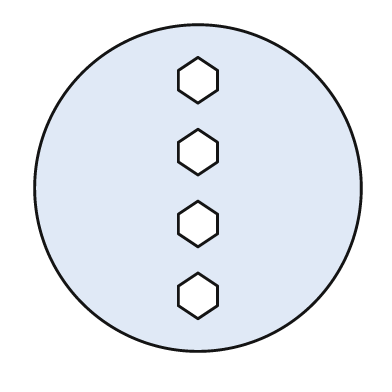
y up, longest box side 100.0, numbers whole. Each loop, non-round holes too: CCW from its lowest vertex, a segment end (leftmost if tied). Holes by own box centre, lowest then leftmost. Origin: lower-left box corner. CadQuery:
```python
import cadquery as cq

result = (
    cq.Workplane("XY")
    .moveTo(50.0, 50.0)
    .circle(50.0)
    .moveTo(50.0, 10.0)
    .lineTo(56.0, 14.0)
    .lineTo(56.0, 20.0)
    .lineTo(50.0, 24.0)
    .lineTo(44.0, 20.0)
    .lineTo(44.0, 14.0)
    .close()
    .moveTo(50.0, 32.0)
    .lineTo(56.0, 36.0)
    .lineTo(56.0, 42.0)
    .lineTo(50.0, 46.0)
    .lineTo(44.0, 42.0)
    .lineTo(44.0, 36.0)
    .close()
    .moveTo(50.0, 54.0)
    .lineTo(56.0, 58.0)
    .lineTo(56.0, 64.0)
    .lineTo(50.0, 68.0)
    .lineTo(44.0, 64.0)
    .lineTo(44.0, 58.0)
    .close()
    .moveTo(50.0, 76.0)
    .lineTo(56.0, 80.0)
    .lineTo(56.0, 86.0)
    .lineTo(50.0, 90.0)
    .lineTo(44.0, 86.0)
    .lineTo(44.0, 80.0)
    .close()
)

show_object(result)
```